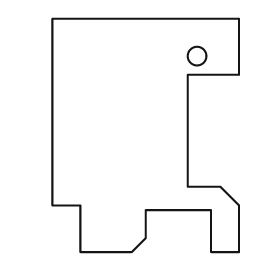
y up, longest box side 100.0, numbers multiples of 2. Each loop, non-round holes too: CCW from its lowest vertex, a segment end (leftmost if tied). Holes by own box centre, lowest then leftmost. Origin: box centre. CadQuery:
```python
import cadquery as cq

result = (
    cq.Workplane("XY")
    .moveTo(-28.0, -50.0)
    .lineTo(-6.0, -50.0)
    .lineTo(0.0, -44.0)
    .lineTo(0.0, -32.0)
    .lineTo(28.0, -32.0)
    .lineTo(28.0, -50.0)
    .lineTo(40.0, -50.0)
    .lineTo(40.0, -30.0)
    .lineTo(32.0, -22.0)
    .lineTo(18.0, -22.0)
    .lineTo(18.0, 26.0)
    .lineTo(40.0, 26.0)
    .lineTo(40.0, 50.0)
    .lineTo(-40.0, 50.0)
    .lineTo(-40.0, -30.0)
    .lineTo(-28.0, -30.0)
    .close()
    .moveTo(22.0, 34.0)
    .circle(4.0)
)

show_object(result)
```